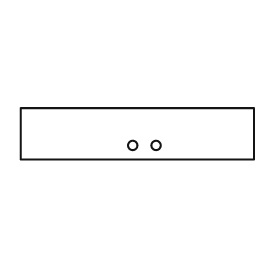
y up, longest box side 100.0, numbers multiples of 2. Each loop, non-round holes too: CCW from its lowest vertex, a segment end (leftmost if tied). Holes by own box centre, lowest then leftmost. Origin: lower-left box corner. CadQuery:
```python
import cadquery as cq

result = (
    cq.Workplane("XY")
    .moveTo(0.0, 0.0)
    .lineTo(100.0, 0.0)
    .lineTo(100.0, 22.0)
    .lineTo(0.0, 22.0)
    .close()
    .moveTo(48.0, 6.0)
    .circle(2.0)
    .moveTo(58.0, 6.0)
    .circle(2.0)
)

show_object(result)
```